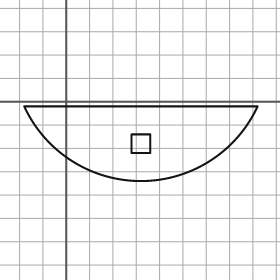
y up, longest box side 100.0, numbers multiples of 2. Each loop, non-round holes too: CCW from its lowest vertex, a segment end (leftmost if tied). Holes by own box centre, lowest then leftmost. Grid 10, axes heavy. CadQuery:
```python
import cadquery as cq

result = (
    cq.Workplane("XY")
    .moveTo(-18.0, -2.0)
    .threePointArc((32.0, -34.0), (82.0, -2.0))
    .close()
    .moveTo(28.0, -22.0)
    .lineTo(36.0, -22.0)
    .lineTo(36.0, -14.0)
    .lineTo(28.0, -14.0)
    .close()
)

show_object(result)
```